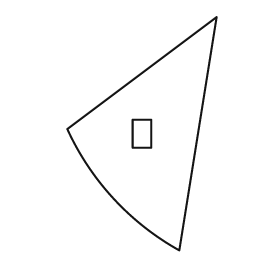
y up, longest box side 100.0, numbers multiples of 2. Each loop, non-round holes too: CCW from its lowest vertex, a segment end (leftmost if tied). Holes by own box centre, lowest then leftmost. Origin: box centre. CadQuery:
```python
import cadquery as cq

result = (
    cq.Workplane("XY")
    .moveTo(16.0, -50.0)
    .lineTo(32.0, 50.0)
    .lineTo(-32.0, 2.0)
    .threePointArc((-12.0, -28.0), (16.0, -50.0))
    .close()
    .moveTo(-4.0, -6.0)
    .lineTo(4.0, -6.0)
    .lineTo(4.0, 6.0)
    .lineTo(-4.0, 6.0)
    .close()
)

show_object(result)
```